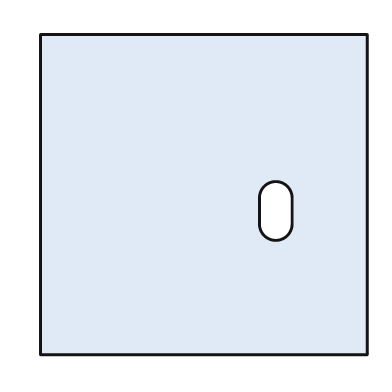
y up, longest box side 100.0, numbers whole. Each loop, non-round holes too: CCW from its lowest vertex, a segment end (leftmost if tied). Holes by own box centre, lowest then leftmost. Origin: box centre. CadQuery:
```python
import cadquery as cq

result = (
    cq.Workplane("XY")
    .moveTo(-50.0, -49.0)
    .lineTo(50.0, -49.0)
    .lineTo(50.0, 49.0)
    .lineTo(-50.0, 49.0)
    .close()
    .moveTo(17.0, -9.0)
    .threePointArc((22.0, -14.0), (27.0, -9.0))
    .lineTo(27.0, -1.0)
    .threePointArc((22.0, 4.0), (17.0, -1.0))
    .close()
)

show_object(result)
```